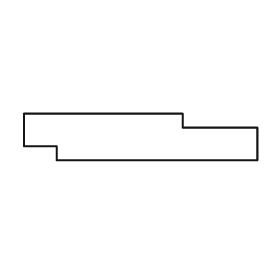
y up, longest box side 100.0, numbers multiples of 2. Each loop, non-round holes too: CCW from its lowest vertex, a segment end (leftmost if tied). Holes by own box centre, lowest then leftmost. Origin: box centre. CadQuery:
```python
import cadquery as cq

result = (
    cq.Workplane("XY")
    .moveTo(-36.0, -10.0)
    .lineTo(50.0, -10.0)
    .lineTo(50.0, 4.0)
    .lineTo(18.0, 4.0)
    .lineTo(18.0, 10.0)
    .lineTo(-50.0, 10.0)
    .lineTo(-50.0, -4.0)
    .lineTo(-36.0, -4.0)
    .close()
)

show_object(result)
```